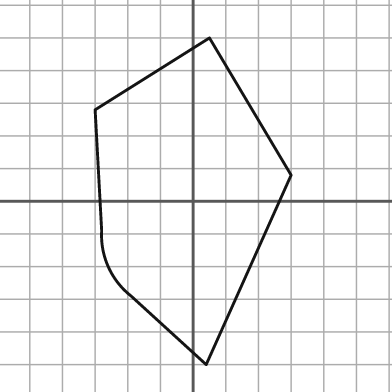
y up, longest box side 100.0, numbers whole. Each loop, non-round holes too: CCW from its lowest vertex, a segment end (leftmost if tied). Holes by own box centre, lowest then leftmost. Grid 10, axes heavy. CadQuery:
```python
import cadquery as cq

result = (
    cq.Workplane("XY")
    .moveTo(4.0, -50.0)
    .lineTo(30.0, 8.0)
    .lineTo(5.0, 50.0)
    .lineTo(-30.0, 28.0)
    .lineTo(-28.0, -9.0)
    .threePointArc((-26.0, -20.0), (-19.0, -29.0))
    .close()
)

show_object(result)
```